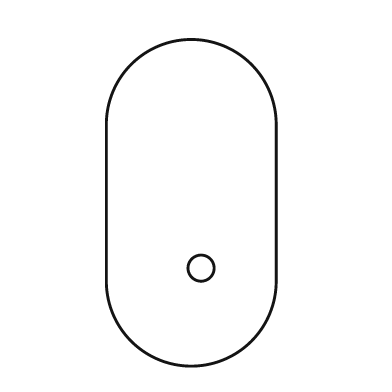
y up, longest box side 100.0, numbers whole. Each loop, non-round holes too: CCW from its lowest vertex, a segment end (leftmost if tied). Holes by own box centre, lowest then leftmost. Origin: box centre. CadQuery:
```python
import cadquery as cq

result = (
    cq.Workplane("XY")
    .moveTo(-26.0, -24.0)
    .threePointArc((0.0, -50.0), (26.0, -24.0))
    .lineTo(26.0, 24.0)
    .threePointArc((0.0, 50.0), (-26.0, 24.0))
    .close()
    .moveTo(3.0, -20.0)
    .circle(4.0)
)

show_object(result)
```